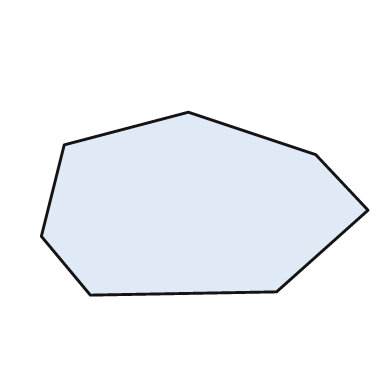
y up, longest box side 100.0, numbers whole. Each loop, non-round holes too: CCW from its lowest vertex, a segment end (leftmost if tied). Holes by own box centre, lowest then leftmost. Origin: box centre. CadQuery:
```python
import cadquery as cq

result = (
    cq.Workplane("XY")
    .moveTo(-35.0, -28.0)
    .lineTo(22.0, -27.0)
    .lineTo(50.0, -2.0)
    .lineTo(34.0, 15.0)
    .lineTo(-5.0, 28.0)
    .lineTo(-43.0, 18.0)
    .lineTo(-50.0, -10.0)
    .close()
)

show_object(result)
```